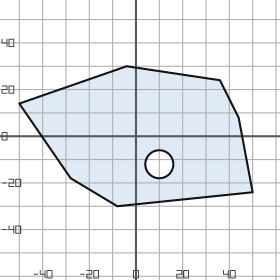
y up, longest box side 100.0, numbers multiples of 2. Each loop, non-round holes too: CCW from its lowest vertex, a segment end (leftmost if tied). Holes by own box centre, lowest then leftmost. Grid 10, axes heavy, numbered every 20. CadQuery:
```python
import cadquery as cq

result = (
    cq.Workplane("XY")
    .moveTo(-8.0, -30.0)
    .lineTo(50.0, -24.0)
    .lineTo(44.0, 8.0)
    .lineTo(36.0, 24.0)
    .lineTo(-4.0, 30.0)
    .lineTo(-50.0, 14.0)
    .lineTo(-28.0, -18.0)
    .close()
    .moveTo(10.0, -12.0)
    .circle(6.0)
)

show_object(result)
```